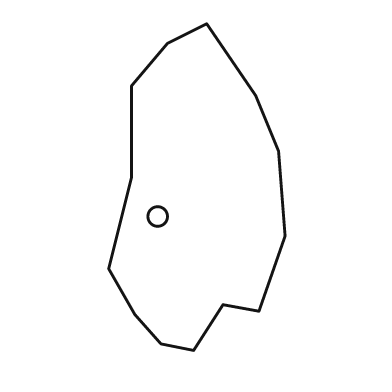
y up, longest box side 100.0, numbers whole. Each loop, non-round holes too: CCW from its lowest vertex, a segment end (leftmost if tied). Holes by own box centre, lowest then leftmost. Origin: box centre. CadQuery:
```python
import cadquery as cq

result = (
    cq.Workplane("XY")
    .moveTo(-1.0, -50.0)
    .lineTo(8.0, -36.0)
    .lineTo(19.0, -38.0)
    .lineTo(27.0, -15.0)
    .lineTo(25.0, 11.0)
    .lineTo(18.0, 28.0)
    .lineTo(3.0, 50.0)
    .lineTo(-9.0, 44.0)
    .lineTo(-20.0, 31.0)
    .lineTo(-20.0, 3.0)
    .lineTo(-27.0, -25.0)
    .lineTo(-19.0, -39.0)
    .lineTo(-11.0, -48.0)
    .close()
    .moveTo(-12.0, -9.0)
    .circle(3.0)
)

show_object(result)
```